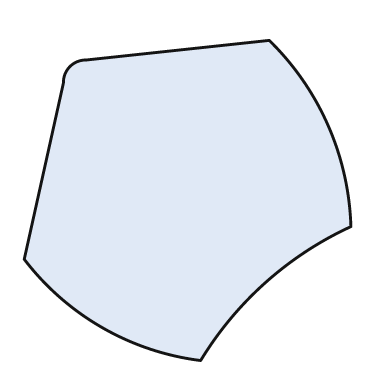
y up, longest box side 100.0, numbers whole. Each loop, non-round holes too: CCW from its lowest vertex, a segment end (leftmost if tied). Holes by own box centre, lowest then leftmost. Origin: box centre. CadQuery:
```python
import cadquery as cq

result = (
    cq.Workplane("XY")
    .moveTo(4.0, -49.0)
    .threePointArc((24.0, -25.0), (50.0, -8.0))
    .threePointArc((43.0, 23.0), (25.0, 49.0))
    .lineTo(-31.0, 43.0)
    .threePointArc((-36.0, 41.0), (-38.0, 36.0))
    .lineTo(-50.0, -18.0)
    .threePointArc((-26.0, -39.0), (4.0, -49.0))
    .close()
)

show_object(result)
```